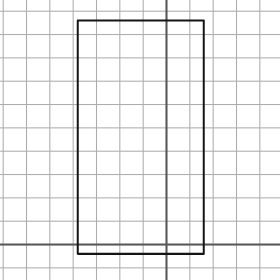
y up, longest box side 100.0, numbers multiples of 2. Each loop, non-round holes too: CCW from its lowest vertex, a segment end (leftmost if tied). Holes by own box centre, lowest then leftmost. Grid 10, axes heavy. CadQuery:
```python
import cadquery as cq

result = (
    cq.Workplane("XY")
    .moveTo(-38.0, -4.0)
    .lineTo(16.0, -4.0)
    .lineTo(16.0, 96.0)
    .lineTo(-38.0, 96.0)
    .close()
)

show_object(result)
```